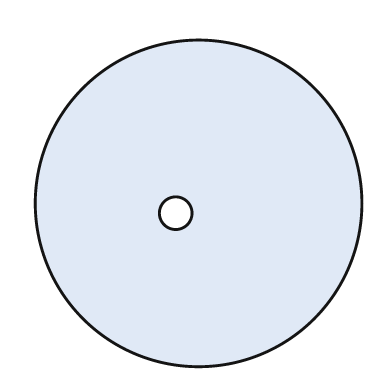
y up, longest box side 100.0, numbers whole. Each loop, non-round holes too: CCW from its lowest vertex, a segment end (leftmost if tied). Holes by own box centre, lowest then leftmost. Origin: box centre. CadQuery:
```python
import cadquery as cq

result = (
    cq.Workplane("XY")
    .moveTo(0.0, 0.0)
    .circle(50.0)
    .moveTo(-7.0, -3.0)
    .circle(5.0)
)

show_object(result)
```